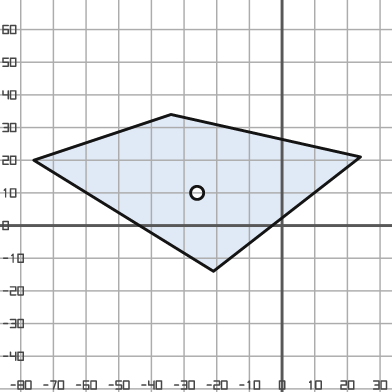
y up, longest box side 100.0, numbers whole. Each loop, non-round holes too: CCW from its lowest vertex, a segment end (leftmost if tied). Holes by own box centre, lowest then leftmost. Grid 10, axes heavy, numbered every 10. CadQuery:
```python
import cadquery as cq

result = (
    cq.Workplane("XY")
    .moveTo(-21.0, -14.0)
    .lineTo(24.0, 21.0)
    .lineTo(-34.0, 34.0)
    .lineTo(-76.0, 20.0)
    .close()
    .moveTo(-26.0, 10.0)
    .circle(2.0)
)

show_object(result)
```